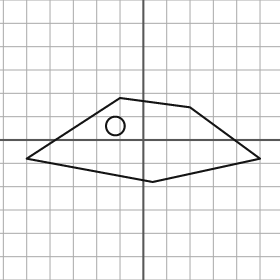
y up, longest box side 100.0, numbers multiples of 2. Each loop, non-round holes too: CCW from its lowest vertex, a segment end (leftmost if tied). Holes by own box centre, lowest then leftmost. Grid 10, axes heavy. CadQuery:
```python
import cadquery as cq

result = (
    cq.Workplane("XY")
    .moveTo(4.0, -18.0)
    .lineTo(50.0, -8.0)
    .lineTo(20.0, 14.0)
    .lineTo(-10.0, 18.0)
    .lineTo(-50.0, -8.0)
    .close()
    .moveTo(-12.0, 6.0)
    .circle(4.0)
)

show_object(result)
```